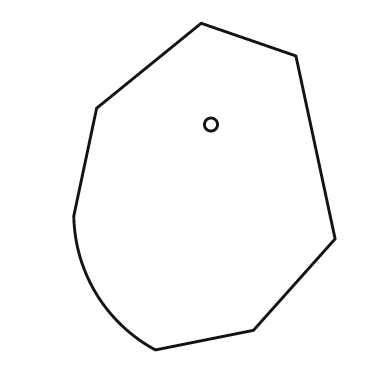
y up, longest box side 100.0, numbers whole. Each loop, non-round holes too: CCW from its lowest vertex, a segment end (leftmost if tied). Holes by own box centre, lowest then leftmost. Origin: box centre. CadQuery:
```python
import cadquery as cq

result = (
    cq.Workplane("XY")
    .moveTo(-15.0, -50.0)
    .lineTo(15.0, -44.0)
    .lineTo(40.0, -16.0)
    .lineTo(28.0, 40.0)
    .lineTo(-1.0, 50.0)
    .lineTo(-33.0, 24.0)
    .lineTo(-40.0, -9.0)
    .threePointArc((-33.0, -33.0), (-15.0, -50.0))
    .close()
    .moveTo(2.0, 19.0)
    .circle(2.0)
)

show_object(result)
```